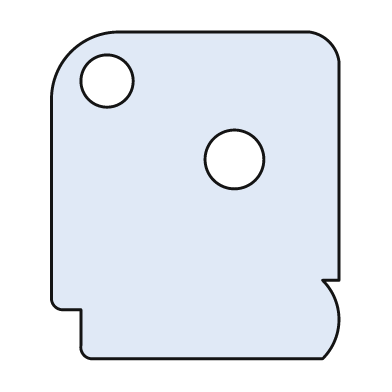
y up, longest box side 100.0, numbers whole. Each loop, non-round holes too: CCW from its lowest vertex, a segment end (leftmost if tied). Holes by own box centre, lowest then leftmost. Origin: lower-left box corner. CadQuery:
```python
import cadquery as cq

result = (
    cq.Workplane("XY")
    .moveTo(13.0, 0.0)
    .lineTo(83.0, 0.0)
    .threePointArc((88.0, 12.0), (83.0, 24.0))
    .lineTo(88.0, 24.0)
    .lineTo(88.0, 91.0)
    .threePointArc((85.0, 97.0), (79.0, 100.0))
    .lineTo(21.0, 100.0)
    .threePointArc((6.0, 94.0), (0.0, 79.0))
    .lineTo(0.0, 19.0)
    .threePointArc((1.0, 16.0), (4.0, 15.0))
    .lineTo(9.0, 15.0)
    .lineTo(9.0, 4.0)
    .threePointArc((10.0, 1.0), (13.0, 0.0))
    .close()
    .moveTo(56.0, 61.0)
    .circle(9.0)
    .moveTo(17.0, 85.0)
    .circle(8.0)
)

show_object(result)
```